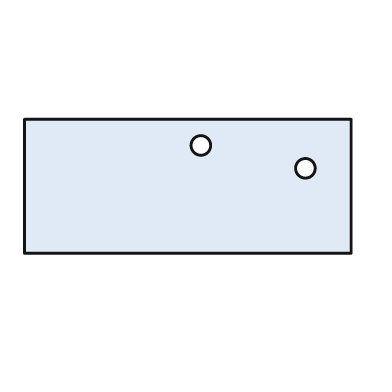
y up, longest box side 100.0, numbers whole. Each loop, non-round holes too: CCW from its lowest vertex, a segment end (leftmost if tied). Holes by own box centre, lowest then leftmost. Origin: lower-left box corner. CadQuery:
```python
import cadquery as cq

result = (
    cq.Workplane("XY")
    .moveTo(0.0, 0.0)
    .lineTo(100.0, 0.0)
    .lineTo(100.0, 41.0)
    .lineTo(0.0, 41.0)
    .close()
    .moveTo(86.0, 26.0)
    .circle(3.0)
    .moveTo(54.0, 33.0)
    .circle(3.0)
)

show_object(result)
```